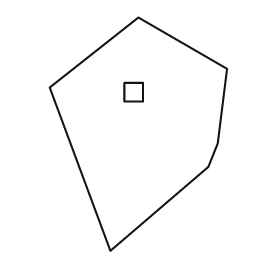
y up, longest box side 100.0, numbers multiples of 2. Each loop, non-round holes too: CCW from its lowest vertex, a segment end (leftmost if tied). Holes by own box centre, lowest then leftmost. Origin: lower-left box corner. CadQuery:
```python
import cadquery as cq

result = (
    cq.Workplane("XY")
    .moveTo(26.0, 0.0)
    .lineTo(68.0, 36.0)
    .lineTo(72.0, 46.0)
    .lineTo(76.0, 78.0)
    .lineTo(38.0, 100.0)
    .lineTo(0.0, 70.0)
    .close()
    .moveTo(32.0, 64.0)
    .lineTo(40.0, 64.0)
    .lineTo(40.0, 72.0)
    .lineTo(32.0, 72.0)
    .close()
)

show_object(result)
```